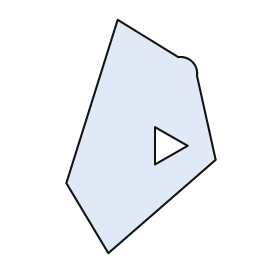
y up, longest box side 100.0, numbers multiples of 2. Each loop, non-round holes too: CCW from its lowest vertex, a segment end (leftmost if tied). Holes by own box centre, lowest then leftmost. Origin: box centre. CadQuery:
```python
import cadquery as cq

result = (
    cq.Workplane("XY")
    .moveTo(-14.0, -50.0)
    .lineTo(32.0, -10.0)
    .lineTo(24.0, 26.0)
    .threePointArc((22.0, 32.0), (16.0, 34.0))
    .lineTo(-10.0, 50.0)
    .lineTo(-32.0, -20.0)
    .close()
    .moveTo(6.0, -12.0)
    .lineTo(20.0, -4.0)
    .lineTo(6.0, 4.0)
    .close()
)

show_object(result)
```